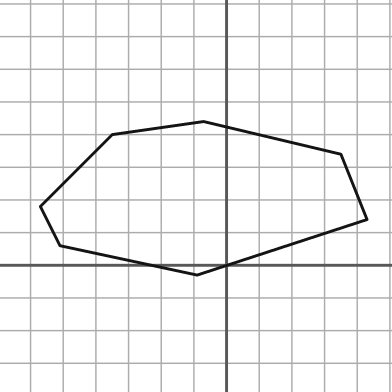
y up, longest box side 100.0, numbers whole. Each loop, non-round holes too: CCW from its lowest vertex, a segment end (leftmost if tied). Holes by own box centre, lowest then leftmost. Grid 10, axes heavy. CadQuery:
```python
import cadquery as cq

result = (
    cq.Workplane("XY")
    .moveTo(-9.0, -3.0)
    .lineTo(43.0, 14.0)
    .lineTo(35.0, 34.0)
    .lineTo(-7.0, 44.0)
    .lineTo(-35.0, 40.0)
    .lineTo(-57.0, 18.0)
    .lineTo(-51.0, 6.0)
    .close()
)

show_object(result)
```